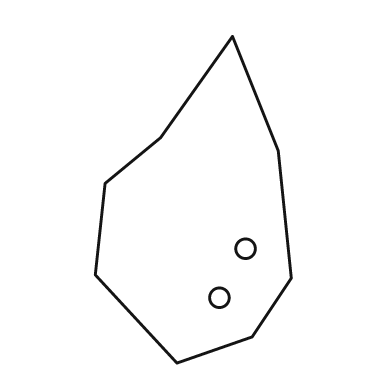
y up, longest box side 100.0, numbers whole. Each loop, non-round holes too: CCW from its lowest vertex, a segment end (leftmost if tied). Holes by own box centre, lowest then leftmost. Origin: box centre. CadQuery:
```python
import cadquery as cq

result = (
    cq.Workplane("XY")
    .moveTo(-5.0, -50.0)
    .lineTo(18.0, -42.0)
    .lineTo(30.0, -24.0)
    .lineTo(26.0, 15.0)
    .lineTo(12.0, 50.0)
    .lineTo(-10.0, 19.0)
    .lineTo(-27.0, 5.0)
    .lineTo(-30.0, -23.0)
    .close()
    .moveTo(8.0, -30.0)
    .circle(3.0)
    .moveTo(16.0, -15.0)
    .circle(3.0)
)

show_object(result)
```